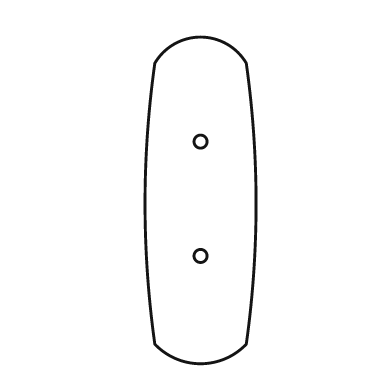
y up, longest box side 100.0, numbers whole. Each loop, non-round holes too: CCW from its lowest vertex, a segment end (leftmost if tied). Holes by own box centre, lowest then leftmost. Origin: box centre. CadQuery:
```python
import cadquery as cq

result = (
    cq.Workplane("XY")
    .moveTo(-14.0, -44.0)
    .threePointArc((0.0, -50.0), (14.0, -44.0))
    .threePointArc((17.0, -1.0), (14.0, 42.0))
    .threePointArc((0.0, 50.0), (-14.0, 42.0))
    .threePointArc((-17.0, -1.0), (-14.0, -44.0))
    .close()
    .moveTo(0.0, -17.0)
    .circle(2.0)
    .moveTo(0.0, 18.0)
    .circle(2.0)
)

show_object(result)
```